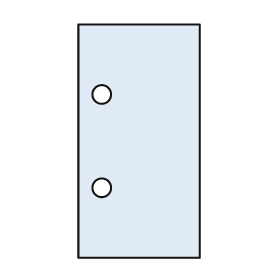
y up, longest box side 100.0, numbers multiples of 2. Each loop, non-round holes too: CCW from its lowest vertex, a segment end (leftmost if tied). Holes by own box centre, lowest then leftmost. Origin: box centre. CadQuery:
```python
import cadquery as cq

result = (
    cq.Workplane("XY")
    .moveTo(-26.0, -50.0)
    .lineTo(26.0, -50.0)
    .lineTo(26.0, 50.0)
    .lineTo(-26.0, 50.0)
    .close()
    .moveTo(-16.0, -20.0)
    .circle(4.0)
    .moveTo(-16.0, 20.0)
    .circle(4.0)
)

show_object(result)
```